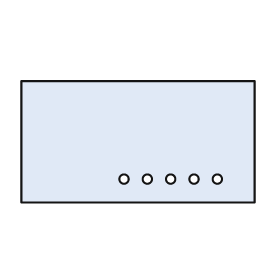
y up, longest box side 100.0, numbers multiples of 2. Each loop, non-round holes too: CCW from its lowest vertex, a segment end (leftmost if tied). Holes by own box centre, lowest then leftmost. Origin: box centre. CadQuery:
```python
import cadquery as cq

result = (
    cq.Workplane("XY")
    .moveTo(-50.0, -26.0)
    .lineTo(50.0, -26.0)
    .lineTo(50.0, 26.0)
    .lineTo(-50.0, 26.0)
    .close()
    .moveTo(-6.0, -16.0)
    .circle(2.0)
    .moveTo(4.0, -16.0)
    .circle(2.0)
    .moveTo(14.0, -16.0)
    .circle(2.0)
    .moveTo(24.0, -16.0)
    .circle(2.0)
    .moveTo(34.0, -16.0)
    .circle(2.0)
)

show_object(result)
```